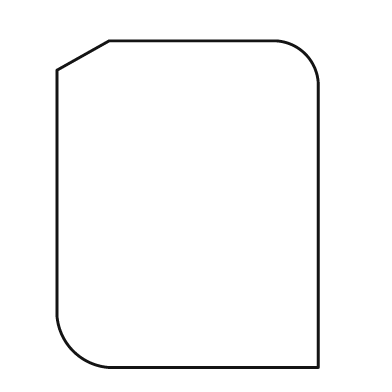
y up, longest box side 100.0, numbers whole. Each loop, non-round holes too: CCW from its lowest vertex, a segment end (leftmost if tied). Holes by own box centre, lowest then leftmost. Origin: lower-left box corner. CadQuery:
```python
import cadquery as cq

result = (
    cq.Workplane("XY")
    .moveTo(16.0, 0.0)
    .lineTo(80.0, 0.0)
    .lineTo(80.0, 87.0)
    .threePointArc((76.0, 96.0), (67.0, 100.0))
    .lineTo(16.0, 100.0)
    .lineTo(0.0, 91.0)
    .lineTo(0.0, 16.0)
    .threePointArc((5.0, 5.0), (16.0, 0.0))
    .close()
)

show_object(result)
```